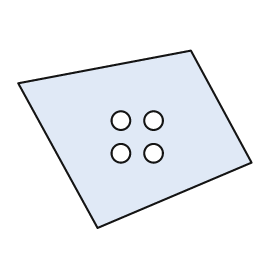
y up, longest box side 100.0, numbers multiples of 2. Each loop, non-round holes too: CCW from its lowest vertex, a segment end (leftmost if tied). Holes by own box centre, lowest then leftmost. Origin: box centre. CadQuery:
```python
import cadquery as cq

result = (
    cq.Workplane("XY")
    .moveTo(-16.0, -38.0)
    .lineTo(50.0, -10.0)
    .lineTo(24.0, 38.0)
    .lineTo(-50.0, 24.0)
    .close()
    .moveTo(-6.0, -6.0)
    .circle(4.0)
    .moveTo(8.0, -6.0)
    .circle(4.0)
    .moveTo(-6.0, 8.0)
    .circle(4.0)
    .moveTo(8.0, 8.0)
    .circle(4.0)
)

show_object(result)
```